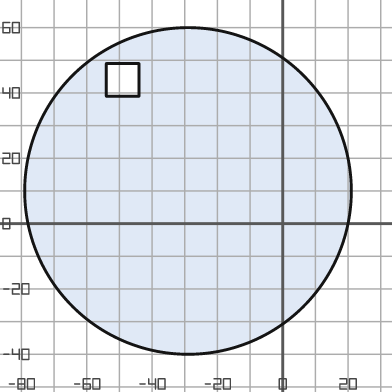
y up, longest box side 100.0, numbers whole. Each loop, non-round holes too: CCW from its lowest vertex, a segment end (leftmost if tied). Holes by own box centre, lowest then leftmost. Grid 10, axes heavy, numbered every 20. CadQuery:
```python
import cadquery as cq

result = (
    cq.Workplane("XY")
    .moveTo(-29.0, 10.0)
    .circle(50.0)
    .moveTo(-54.0, 39.0)
    .lineTo(-44.0, 39.0)
    .lineTo(-44.0, 49.0)
    .lineTo(-54.0, 49.0)
    .close()
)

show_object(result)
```